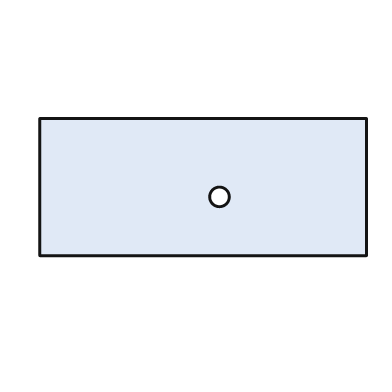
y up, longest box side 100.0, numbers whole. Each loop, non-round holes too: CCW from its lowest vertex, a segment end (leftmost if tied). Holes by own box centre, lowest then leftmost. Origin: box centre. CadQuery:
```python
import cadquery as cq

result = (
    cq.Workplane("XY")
    .moveTo(-50.0, -21.0)
    .lineTo(50.0, -21.0)
    .lineTo(50.0, 21.0)
    .lineTo(-50.0, 21.0)
    .close()
    .moveTo(5.0, -3.0)
    .circle(3.0)
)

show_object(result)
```